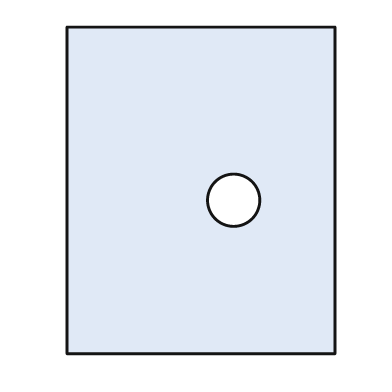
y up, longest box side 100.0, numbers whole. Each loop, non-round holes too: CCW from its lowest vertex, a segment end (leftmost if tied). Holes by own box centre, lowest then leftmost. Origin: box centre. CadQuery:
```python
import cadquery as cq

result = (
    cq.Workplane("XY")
    .moveTo(-41.0, -50.0)
    .lineTo(41.0, -50.0)
    .lineTo(41.0, 50.0)
    .lineTo(-41.0, 50.0)
    .close()
    .moveTo(10.0, -3.0)
    .circle(8.0)
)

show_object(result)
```